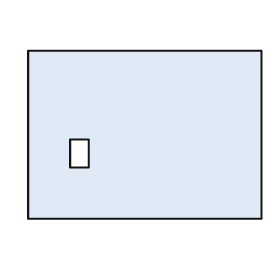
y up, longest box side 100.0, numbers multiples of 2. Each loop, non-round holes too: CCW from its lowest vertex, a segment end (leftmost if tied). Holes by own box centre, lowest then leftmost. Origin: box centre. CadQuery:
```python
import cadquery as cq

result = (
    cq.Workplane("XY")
    .moveTo(-50.0, -36.0)
    .lineTo(50.0, -36.0)
    .lineTo(50.0, 36.0)
    .lineTo(-50.0, 36.0)
    .close()
    .moveTo(-32.0, -14.0)
    .lineTo(-24.0, -14.0)
    .lineTo(-24.0, -2.0)
    .lineTo(-32.0, -2.0)
    .close()
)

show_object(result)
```